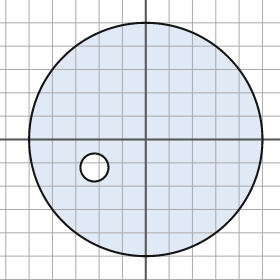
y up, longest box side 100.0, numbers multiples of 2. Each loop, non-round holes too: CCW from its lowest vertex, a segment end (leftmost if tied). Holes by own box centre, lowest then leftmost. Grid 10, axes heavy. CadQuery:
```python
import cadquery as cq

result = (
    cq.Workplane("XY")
    .moveTo(0.0, 0.0)
    .circle(50.0)
    .moveTo(-22.0, -12.0)
    .circle(6.0)
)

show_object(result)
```